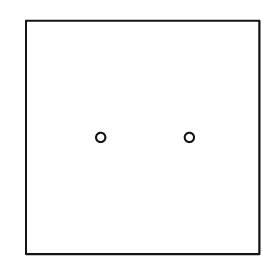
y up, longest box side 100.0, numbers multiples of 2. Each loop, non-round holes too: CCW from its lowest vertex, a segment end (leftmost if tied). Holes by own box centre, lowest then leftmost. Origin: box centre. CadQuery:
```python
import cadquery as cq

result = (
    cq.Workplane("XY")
    .moveTo(-50.0, -50.0)
    .lineTo(50.0, -50.0)
    .lineTo(50.0, 50.0)
    .lineTo(-50.0, 50.0)
    .close()
    .moveTo(-18.0, 0.0)
    .circle(2.0)
    .moveTo(20.0, 0.0)
    .circle(2.0)
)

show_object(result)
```